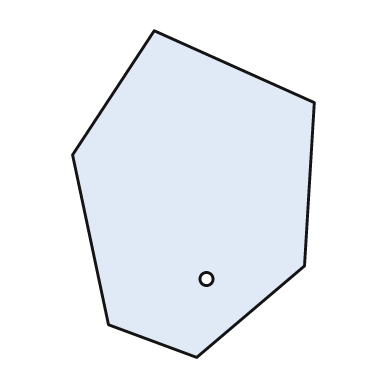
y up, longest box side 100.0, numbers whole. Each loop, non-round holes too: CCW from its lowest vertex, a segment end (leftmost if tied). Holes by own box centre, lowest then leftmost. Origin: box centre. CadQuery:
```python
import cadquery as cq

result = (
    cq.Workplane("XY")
    .moveTo(1.0, -50.0)
    .lineTo(34.0, -22.0)
    .lineTo(37.0, 28.0)
    .lineTo(-12.0, 50.0)
    .lineTo(-37.0, 12.0)
    .lineTo(-26.0, -40.0)
    .close()
    .moveTo(4.0, -26.0)
    .circle(2.0)
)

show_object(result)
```